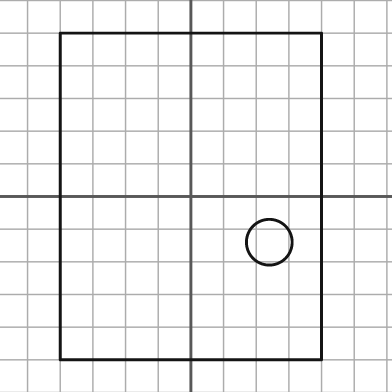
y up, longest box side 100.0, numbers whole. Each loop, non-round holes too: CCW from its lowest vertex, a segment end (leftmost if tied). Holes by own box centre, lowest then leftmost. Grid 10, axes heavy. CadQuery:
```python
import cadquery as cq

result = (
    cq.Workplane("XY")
    .moveTo(-40.0, -50.0)
    .lineTo(40.0, -50.0)
    .lineTo(40.0, 50.0)
    .lineTo(-40.0, 50.0)
    .close()
    .moveTo(24.0, -14.0)
    .circle(7.0)
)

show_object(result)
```